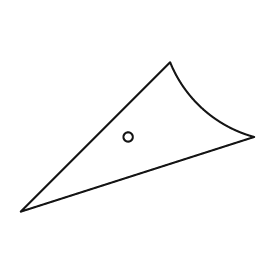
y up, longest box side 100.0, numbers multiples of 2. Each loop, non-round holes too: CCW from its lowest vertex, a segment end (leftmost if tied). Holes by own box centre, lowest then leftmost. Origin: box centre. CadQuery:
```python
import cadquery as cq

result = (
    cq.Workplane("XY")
    .moveTo(-50.0, -32.0)
    .lineTo(50.0, 0.0)
    .threePointArc((28.0, 12.0), (14.0, 32.0))
    .close()
    .moveTo(-4.0, 0.0)
    .circle(2.0)
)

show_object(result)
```